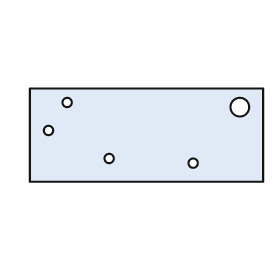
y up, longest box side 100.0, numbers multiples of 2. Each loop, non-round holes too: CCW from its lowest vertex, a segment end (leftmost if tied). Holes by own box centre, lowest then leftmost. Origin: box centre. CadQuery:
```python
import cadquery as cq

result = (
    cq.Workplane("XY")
    .moveTo(-50.0, -20.0)
    .lineTo(50.0, -20.0)
    .lineTo(50.0, 20.0)
    .lineTo(-50.0, 20.0)
    .close()
    .moveTo(20.0, -12.0)
    .circle(2.0)
    .moveTo(-16.0, -10.0)
    .circle(2.0)
    .moveTo(-42.0, 2.0)
    .circle(2.0)
    .moveTo(40.0, 12.0)
    .circle(4.0)
    .moveTo(-34.0, 14.0)
    .circle(2.0)
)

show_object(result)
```